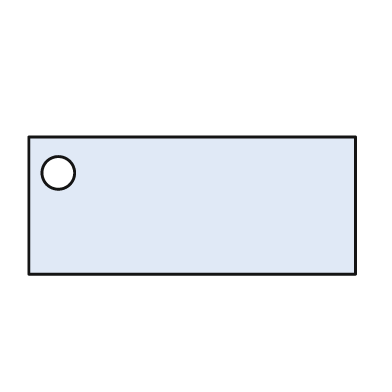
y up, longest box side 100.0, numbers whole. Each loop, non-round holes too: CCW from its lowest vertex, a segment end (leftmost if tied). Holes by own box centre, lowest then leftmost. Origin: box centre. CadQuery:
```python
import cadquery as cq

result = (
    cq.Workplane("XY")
    .moveTo(-50.0, -21.0)
    .lineTo(50.0, -21.0)
    .lineTo(50.0, 21.0)
    .lineTo(-50.0, 21.0)
    .close()
    .moveTo(-41.0, 10.0)
    .circle(5.0)
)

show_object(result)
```